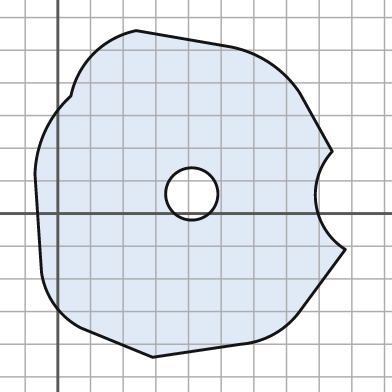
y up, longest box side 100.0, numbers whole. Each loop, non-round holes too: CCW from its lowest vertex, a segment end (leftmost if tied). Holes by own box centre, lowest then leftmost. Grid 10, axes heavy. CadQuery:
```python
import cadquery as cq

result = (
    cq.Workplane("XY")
    .moveTo(29.0, -44.0)
    .lineTo(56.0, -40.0)
    .threePointArc((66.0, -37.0), (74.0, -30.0))
    .lineTo(88.0, -11.0)
    .threePointArc((79.0, 3.0), (84.0, 19.0))
    .lineTo(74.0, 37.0)
    .threePointArc((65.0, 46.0), (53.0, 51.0))
    .lineTo(24.0, 56.0)
    .threePointArc((11.0, 49.0), (4.0, 36.0))
    .threePointArc((-4.0, 25.0), (-7.0, 12.0))
    .lineTo(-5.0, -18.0)
    .threePointArc((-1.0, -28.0), (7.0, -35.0))
    .close()
    .moveTo(41.0, 6.0)
    .circle(8.0)
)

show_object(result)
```